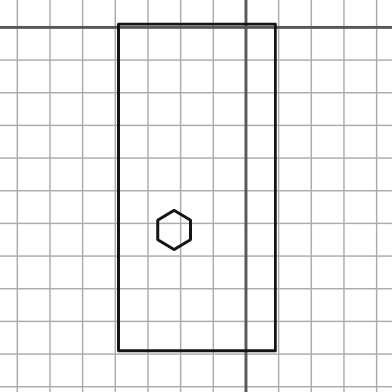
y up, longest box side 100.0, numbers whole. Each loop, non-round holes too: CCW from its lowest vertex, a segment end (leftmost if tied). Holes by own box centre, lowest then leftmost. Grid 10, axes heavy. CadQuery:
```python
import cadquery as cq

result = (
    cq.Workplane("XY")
    .moveTo(-39.0, -99.0)
    .lineTo(9.0, -99.0)
    .lineTo(9.0, 1.0)
    .lineTo(-39.0, 1.0)
    .close()
    .moveTo(-22.0, -68.0)
    .lineTo(-17.0, -65.0)
    .lineTo(-17.0, -59.0)
    .lineTo(-22.0, -56.0)
    .lineTo(-27.0, -59.0)
    .lineTo(-27.0, -65.0)
    .close()
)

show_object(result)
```